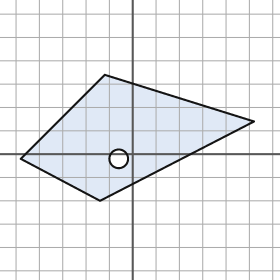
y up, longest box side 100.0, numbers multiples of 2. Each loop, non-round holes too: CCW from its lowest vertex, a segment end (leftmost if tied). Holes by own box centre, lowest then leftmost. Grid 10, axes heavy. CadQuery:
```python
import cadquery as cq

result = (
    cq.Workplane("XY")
    .moveTo(-14.0, -20.0)
    .lineTo(52.0, 14.0)
    .lineTo(-12.0, 34.0)
    .lineTo(-48.0, -2.0)
    .close()
    .moveTo(-6.0, -2.0)
    .circle(4.0)
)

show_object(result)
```